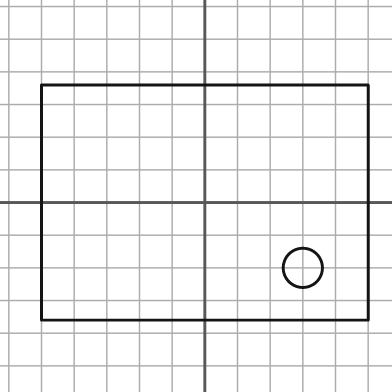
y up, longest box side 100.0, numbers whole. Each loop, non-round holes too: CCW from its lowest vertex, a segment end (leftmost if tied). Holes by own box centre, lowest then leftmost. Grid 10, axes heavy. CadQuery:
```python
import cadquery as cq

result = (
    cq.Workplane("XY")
    .moveTo(-50.0, -36.0)
    .lineTo(50.0, -36.0)
    .lineTo(50.0, 36.0)
    .lineTo(-50.0, 36.0)
    .close()
    .moveTo(30.0, -20.0)
    .circle(6.0)
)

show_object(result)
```